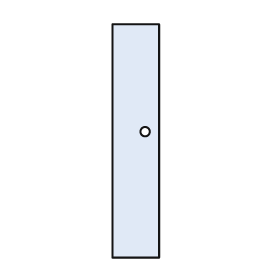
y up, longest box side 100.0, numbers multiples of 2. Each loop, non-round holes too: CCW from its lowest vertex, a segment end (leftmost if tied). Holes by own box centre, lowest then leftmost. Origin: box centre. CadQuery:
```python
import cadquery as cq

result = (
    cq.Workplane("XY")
    .moveTo(-10.0, -50.0)
    .lineTo(10.0, -50.0)
    .lineTo(10.0, 50.0)
    .lineTo(-10.0, 50.0)
    .close()
    .moveTo(4.0, 4.0)
    .circle(2.0)
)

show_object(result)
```